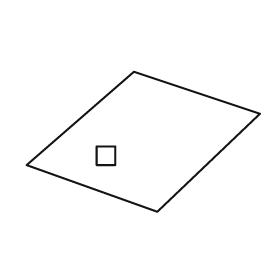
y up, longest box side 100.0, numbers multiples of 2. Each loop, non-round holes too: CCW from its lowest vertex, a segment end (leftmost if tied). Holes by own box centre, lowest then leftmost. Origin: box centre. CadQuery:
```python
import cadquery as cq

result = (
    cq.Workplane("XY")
    .moveTo(6.0, -30.0)
    .lineTo(50.0, 12.0)
    .lineTo(-4.0, 30.0)
    .lineTo(-50.0, -10.0)
    .close()
    .moveTo(-20.0, -10.0)
    .lineTo(-12.0, -10.0)
    .lineTo(-12.0, -2.0)
    .lineTo(-20.0, -2.0)
    .close()
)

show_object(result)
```